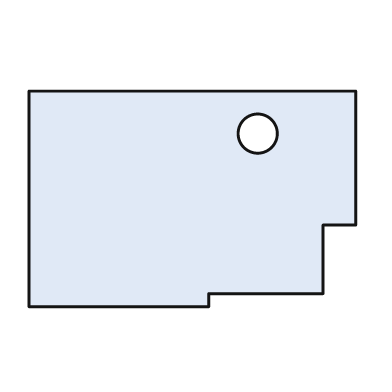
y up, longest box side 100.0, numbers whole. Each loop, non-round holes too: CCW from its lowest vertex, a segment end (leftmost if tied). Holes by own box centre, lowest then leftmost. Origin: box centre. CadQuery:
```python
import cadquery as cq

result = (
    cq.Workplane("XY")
    .moveTo(-50.0, -33.0)
    .lineTo(5.0, -33.0)
    .lineTo(5.0, -29.0)
    .lineTo(40.0, -29.0)
    .lineTo(40.0, -8.0)
    .lineTo(50.0, -8.0)
    .lineTo(50.0, 33.0)
    .lineTo(-50.0, 33.0)
    .close()
    .moveTo(20.0, 20.0)
    .circle(6.0)
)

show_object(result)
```